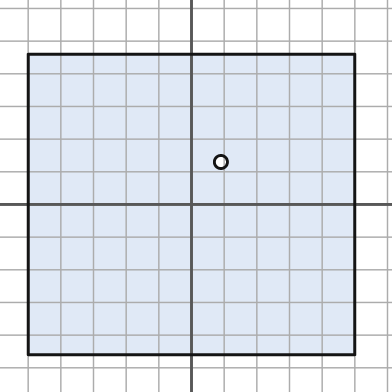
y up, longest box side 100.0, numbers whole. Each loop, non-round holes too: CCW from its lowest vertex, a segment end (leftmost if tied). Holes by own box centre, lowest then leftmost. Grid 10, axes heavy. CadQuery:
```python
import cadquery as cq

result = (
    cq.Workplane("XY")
    .moveTo(-50.0, -46.0)
    .lineTo(50.0, -46.0)
    .lineTo(50.0, 46.0)
    .lineTo(-50.0, 46.0)
    .close()
    .moveTo(9.0, 13.0)
    .circle(2.0)
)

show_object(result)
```